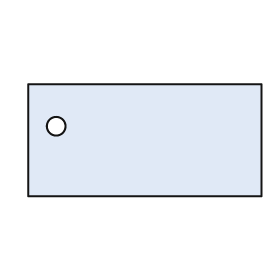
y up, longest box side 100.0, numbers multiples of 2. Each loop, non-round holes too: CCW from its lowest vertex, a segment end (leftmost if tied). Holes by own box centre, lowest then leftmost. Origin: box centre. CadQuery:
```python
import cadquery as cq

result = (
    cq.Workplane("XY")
    .moveTo(-50.0, -24.0)
    .lineTo(50.0, -24.0)
    .lineTo(50.0, 24.0)
    .lineTo(-50.0, 24.0)
    .close()
    .moveTo(-38.0, 6.0)
    .circle(4.0)
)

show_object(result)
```